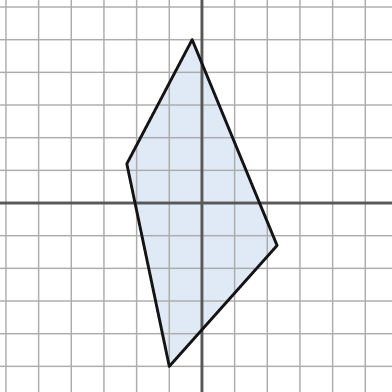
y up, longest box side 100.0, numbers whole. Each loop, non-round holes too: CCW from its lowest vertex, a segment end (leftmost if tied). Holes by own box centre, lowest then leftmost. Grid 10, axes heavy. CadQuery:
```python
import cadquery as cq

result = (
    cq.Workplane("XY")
    .moveTo(-10.0, -50.0)
    .lineTo(23.0, -13.0)
    .lineTo(-3.0, 50.0)
    .lineTo(-23.0, 12.0)
    .close()
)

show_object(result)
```